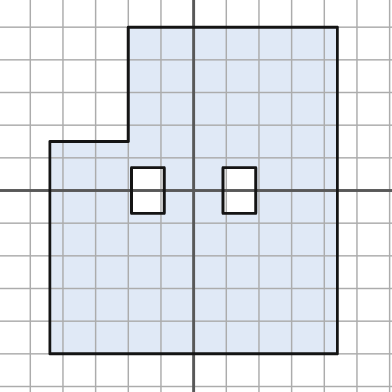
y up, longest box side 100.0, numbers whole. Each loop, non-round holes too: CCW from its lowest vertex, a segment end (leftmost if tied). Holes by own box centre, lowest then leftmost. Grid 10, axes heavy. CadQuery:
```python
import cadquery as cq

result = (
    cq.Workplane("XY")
    .moveTo(-44.0, -50.0)
    .lineTo(44.0, -50.0)
    .lineTo(44.0, 50.0)
    .lineTo(-20.0, 50.0)
    .lineTo(-20.0, 15.0)
    .lineTo(-44.0, 15.0)
    .close()
    .moveTo(-19.0, -7.0)
    .lineTo(-9.0, -7.0)
    .lineTo(-9.0, 7.0)
    .lineTo(-19.0, 7.0)
    .close()
    .moveTo(9.0, -7.0)
    .lineTo(19.0, -7.0)
    .lineTo(19.0, 7.0)
    .lineTo(9.0, 7.0)
    .close()
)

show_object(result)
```